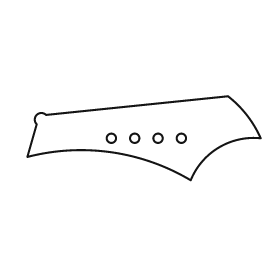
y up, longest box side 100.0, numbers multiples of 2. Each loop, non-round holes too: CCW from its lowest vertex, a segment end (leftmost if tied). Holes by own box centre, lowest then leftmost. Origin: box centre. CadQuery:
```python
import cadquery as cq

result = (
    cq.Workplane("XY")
    .moveTo(20.0, -18.0)
    .threePointArc((32.0, -4.0), (50.0, 0.0))
    .threePointArc((44.0, 10.0), (36.0, 18.0))
    .lineTo(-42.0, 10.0)
    .threePointArc((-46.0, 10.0), (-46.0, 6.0))
    .lineTo(-50.0, -8.0)
    .threePointArc((-14.0, -6.0), (20.0, -18.0))
    .close()
    .moveTo(-14.0, 0.0)
    .circle(2.0)
    .moveTo(-4.0, 0.0)
    .circle(2.0)
    .moveTo(6.0, 0.0)
    .circle(2.0)
    .moveTo(16.0, 0.0)
    .circle(2.0)
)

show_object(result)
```